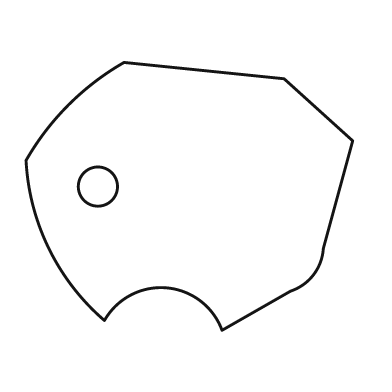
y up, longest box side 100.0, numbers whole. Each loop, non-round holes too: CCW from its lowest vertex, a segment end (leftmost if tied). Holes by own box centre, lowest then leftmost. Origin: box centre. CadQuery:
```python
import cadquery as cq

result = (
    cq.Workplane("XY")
    .moveTo(10.0, -41.0)
    .lineTo(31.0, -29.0)
    .threePointArc((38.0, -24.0), (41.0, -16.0))
    .lineTo(50.0, 17.0)
    .lineTo(29.0, 36.0)
    .lineTo(-20.0, 41.0)
    .threePointArc((-37.0, 28.0), (-50.0, 11.0))
    .threePointArc((-43.0, -16.0), (-26.0, -38.0))
    .threePointArc((-7.0, -28.0), (10.0, -41.0))
    .close()
    .moveTo(-28.0, 3.0)
    .circle(6.0)
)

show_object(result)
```